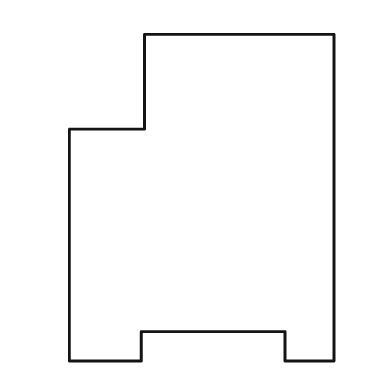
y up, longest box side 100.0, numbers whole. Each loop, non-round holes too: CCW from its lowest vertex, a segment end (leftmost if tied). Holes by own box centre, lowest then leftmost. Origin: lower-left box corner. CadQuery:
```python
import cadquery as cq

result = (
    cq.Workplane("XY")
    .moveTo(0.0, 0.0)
    .lineTo(22.0, 0.0)
    .lineTo(22.0, 9.0)
    .lineTo(66.0, 9.0)
    .lineTo(66.0, 0.0)
    .lineTo(81.0, 0.0)
    .lineTo(81.0, 100.0)
    .lineTo(23.0, 100.0)
    .lineTo(23.0, 71.0)
    .lineTo(0.0, 71.0)
    .close()
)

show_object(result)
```